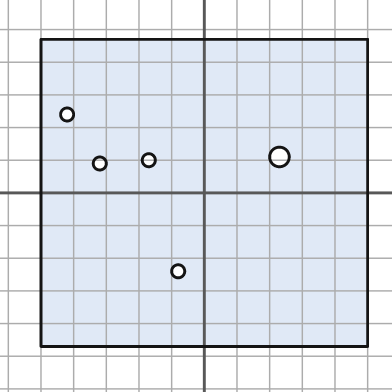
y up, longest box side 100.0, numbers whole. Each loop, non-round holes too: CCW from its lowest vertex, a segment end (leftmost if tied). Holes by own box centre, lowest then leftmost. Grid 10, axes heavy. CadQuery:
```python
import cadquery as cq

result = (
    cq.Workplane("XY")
    .moveTo(-50.0, -47.0)
    .lineTo(50.0, -47.0)
    .lineTo(50.0, 47.0)
    .lineTo(-50.0, 47.0)
    .close()
    .moveTo(-8.0, -24.0)
    .circle(2.0)
    .moveTo(-32.0, 9.0)
    .circle(2.0)
    .moveTo(-17.0, 10.0)
    .circle(2.0)
    .moveTo(23.0, 11.0)
    .circle(3.0)
    .moveTo(-42.0, 24.0)
    .circle(2.0)
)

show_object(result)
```